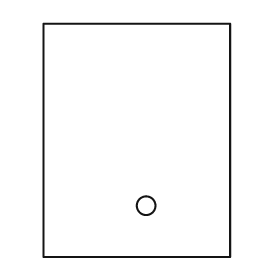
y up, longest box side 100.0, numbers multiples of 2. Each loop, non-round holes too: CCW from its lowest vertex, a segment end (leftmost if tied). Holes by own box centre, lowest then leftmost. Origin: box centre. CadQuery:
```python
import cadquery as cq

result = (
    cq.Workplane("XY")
    .moveTo(-40.0, -50.0)
    .lineTo(40.0, -50.0)
    .lineTo(40.0, 50.0)
    .lineTo(-40.0, 50.0)
    .close()
    .moveTo(4.0, -28.0)
    .circle(4.0)
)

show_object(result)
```